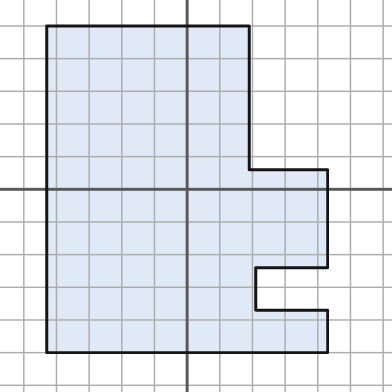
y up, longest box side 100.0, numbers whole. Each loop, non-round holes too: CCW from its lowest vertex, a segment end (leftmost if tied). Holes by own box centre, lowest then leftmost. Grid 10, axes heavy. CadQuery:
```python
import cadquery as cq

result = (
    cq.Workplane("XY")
    .moveTo(-43.0, -50.0)
    .lineTo(43.0, -50.0)
    .lineTo(43.0, -37.0)
    .lineTo(21.0, -37.0)
    .lineTo(21.0, -24.0)
    .lineTo(43.0, -24.0)
    .lineTo(43.0, 6.0)
    .lineTo(19.0, 6.0)
    .lineTo(19.0, 50.0)
    .lineTo(-43.0, 50.0)
    .close()
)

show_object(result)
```